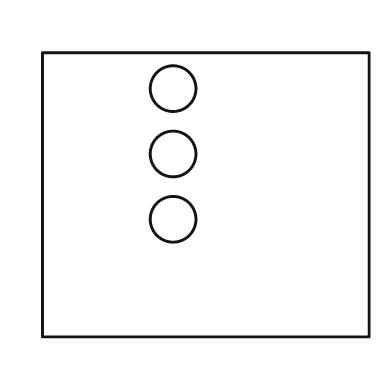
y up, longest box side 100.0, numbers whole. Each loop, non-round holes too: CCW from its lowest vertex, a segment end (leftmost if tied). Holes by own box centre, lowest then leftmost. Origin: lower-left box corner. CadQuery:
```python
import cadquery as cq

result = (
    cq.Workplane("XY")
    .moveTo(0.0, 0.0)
    .lineTo(100.0, 0.0)
    .lineTo(100.0, 87.0)
    .lineTo(0.0, 87.0)
    .close()
    .moveTo(40.0, 36.0)
    .circle(7.0)
    .moveTo(40.0, 56.0)
    .circle(7.0)
    .moveTo(40.0, 76.0)
    .circle(7.0)
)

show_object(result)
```